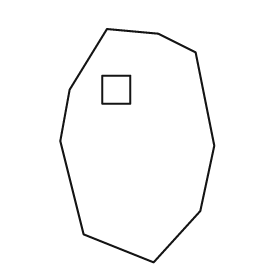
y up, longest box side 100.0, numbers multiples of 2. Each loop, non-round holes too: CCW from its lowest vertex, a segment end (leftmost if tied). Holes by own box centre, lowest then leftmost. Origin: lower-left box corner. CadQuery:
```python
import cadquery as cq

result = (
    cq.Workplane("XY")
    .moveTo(40.0, 0.0)
    .lineTo(60.0, 22.0)
    .lineTo(66.0, 50.0)
    .lineTo(58.0, 90.0)
    .lineTo(42.0, 98.0)
    .lineTo(20.0, 100.0)
    .lineTo(4.0, 74.0)
    .lineTo(0.0, 52.0)
    .lineTo(10.0, 12.0)
    .close()
    .moveTo(18.0, 68.0)
    .lineTo(30.0, 68.0)
    .lineTo(30.0, 80.0)
    .lineTo(18.0, 80.0)
    .close()
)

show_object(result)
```